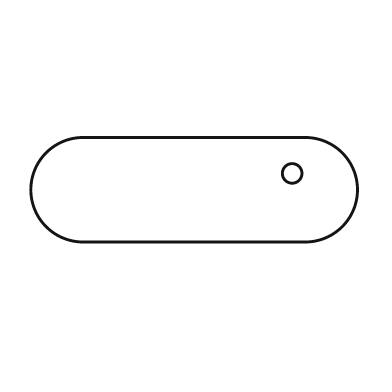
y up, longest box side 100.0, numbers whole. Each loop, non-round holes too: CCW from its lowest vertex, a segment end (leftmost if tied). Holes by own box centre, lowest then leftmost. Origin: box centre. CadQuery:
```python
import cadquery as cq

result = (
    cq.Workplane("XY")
    .moveTo(-34.0, -16.0)
    .lineTo(34.0, -16.0)
    .threePointArc((50.0, 0.0), (34.0, 16.0))
    .lineTo(-34.0, 16.0)
    .threePointArc((-50.0, 0.0), (-34.0, -16.0))
    .close()
    .moveTo(30.0, 5.0)
    .circle(3.0)
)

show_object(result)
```